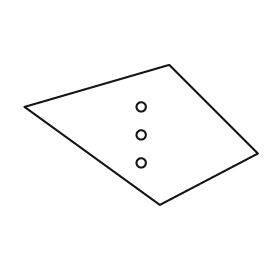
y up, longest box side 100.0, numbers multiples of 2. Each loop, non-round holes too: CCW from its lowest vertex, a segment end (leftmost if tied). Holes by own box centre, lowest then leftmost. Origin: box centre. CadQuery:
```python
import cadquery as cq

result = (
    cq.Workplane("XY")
    .moveTo(8.0, -30.0)
    .lineTo(50.0, -8.0)
    .lineTo(12.0, 30.0)
    .lineTo(-50.0, 12.0)
    .close()
    .moveTo(0.0, -12.0)
    .circle(2.0)
    .moveTo(0.0, 0.0)
    .circle(2.0)
    .moveTo(0.0, 12.0)
    .circle(2.0)
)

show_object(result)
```